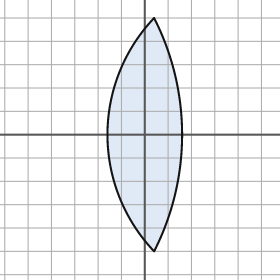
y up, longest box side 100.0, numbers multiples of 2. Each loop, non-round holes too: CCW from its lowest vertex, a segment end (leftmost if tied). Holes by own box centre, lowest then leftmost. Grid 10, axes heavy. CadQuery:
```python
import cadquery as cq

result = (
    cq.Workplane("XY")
    .moveTo(4.0, -50.0)
    .threePointArc((16.0, 0.0), (4.0, 50.0))
    .threePointArc((-16.0, 0.0), (4.0, -50.0))
    .close()
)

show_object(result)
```